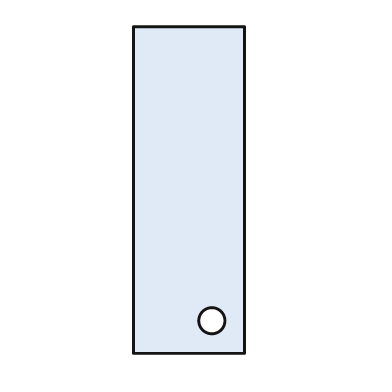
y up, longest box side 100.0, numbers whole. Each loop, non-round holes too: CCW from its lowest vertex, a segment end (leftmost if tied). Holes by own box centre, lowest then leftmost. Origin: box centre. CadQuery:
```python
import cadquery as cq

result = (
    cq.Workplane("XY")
    .moveTo(-17.0, -50.0)
    .lineTo(17.0, -50.0)
    .lineTo(17.0, 50.0)
    .lineTo(-17.0, 50.0)
    .close()
    .moveTo(7.0, -40.0)
    .circle(4.0)
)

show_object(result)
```